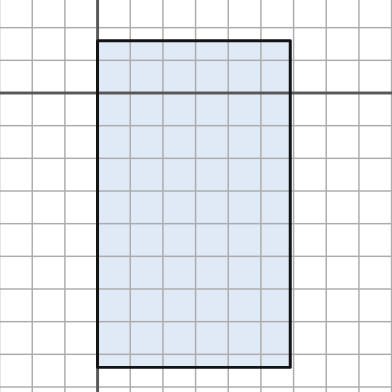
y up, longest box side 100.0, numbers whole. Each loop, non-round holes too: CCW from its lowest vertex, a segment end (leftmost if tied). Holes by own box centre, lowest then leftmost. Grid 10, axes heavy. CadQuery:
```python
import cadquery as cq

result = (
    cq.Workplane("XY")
    .moveTo(0.0, -84.0)
    .lineTo(59.0, -84.0)
    .lineTo(59.0, 16.0)
    .lineTo(0.0, 16.0)
    .close()
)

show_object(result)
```